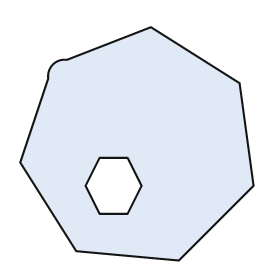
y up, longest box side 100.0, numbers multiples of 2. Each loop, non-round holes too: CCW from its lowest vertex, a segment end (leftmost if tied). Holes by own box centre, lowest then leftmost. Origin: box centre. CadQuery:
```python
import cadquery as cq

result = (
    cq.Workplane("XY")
    .moveTo(18.0, -50.0)
    .lineTo(50.0, -18.0)
    .lineTo(44.0, 26.0)
    .lineTo(6.0, 50.0)
    .lineTo(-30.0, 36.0)
    .threePointArc((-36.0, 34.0), (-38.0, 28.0))
    .lineTo(-50.0, -8.0)
    .lineTo(-26.0, -46.0)
    .close()
    .moveTo(-16.0, -30.0)
    .lineTo(-4.0, -30.0)
    .lineTo(2.0, -18.0)
    .lineTo(-4.0, -6.0)
    .lineTo(-16.0, -6.0)
    .lineTo(-22.0, -18.0)
    .close()
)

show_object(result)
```